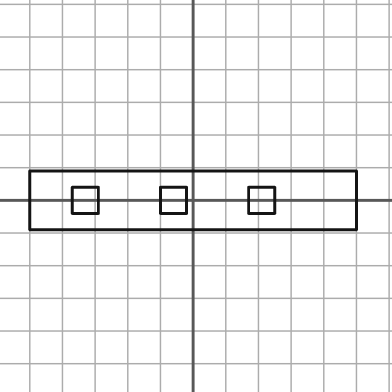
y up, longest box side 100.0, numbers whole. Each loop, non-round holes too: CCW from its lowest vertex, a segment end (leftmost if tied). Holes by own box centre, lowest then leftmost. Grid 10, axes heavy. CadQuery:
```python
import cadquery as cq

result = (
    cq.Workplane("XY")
    .moveTo(-50.0, -9.0)
    .lineTo(50.0, -9.0)
    .lineTo(50.0, 9.0)
    .lineTo(-50.0, 9.0)
    .close()
    .moveTo(-37.0, -4.0)
    .lineTo(-29.0, -4.0)
    .lineTo(-29.0, 4.0)
    .lineTo(-37.0, 4.0)
    .close()
    .moveTo(-10.0, -4.0)
    .lineTo(-2.0, -4.0)
    .lineTo(-2.0, 4.0)
    .lineTo(-10.0, 4.0)
    .close()
    .moveTo(17.0, -4.0)
    .lineTo(25.0, -4.0)
    .lineTo(25.0, 4.0)
    .lineTo(17.0, 4.0)
    .close()
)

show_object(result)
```